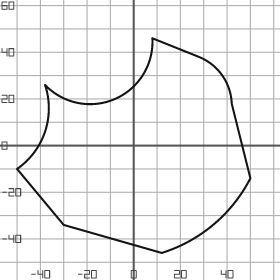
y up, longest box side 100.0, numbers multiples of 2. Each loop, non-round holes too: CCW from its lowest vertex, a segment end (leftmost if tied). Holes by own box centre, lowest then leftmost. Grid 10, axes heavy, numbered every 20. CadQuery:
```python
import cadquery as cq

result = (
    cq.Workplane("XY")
    .moveTo(12.0, -46.0)
    .threePointArc((34.0, -34.0), (50.0, -14.0))
    .lineTo(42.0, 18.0)
    .threePointArc((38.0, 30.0), (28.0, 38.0))
    .lineTo(8.0, 46.0)
    .threePointArc((-8.0, 20.0), (-38.0, 26.0))
    .threePointArc((-38.0, 6.0), (-50.0, -10.0))
    .lineTo(-30.0, -34.0)
    .close()
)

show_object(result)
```